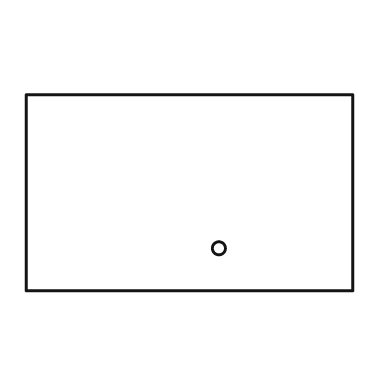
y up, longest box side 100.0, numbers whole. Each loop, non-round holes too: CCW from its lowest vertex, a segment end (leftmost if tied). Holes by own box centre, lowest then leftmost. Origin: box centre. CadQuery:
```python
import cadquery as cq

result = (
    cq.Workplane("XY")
    .moveTo(-50.0, -30.0)
    .lineTo(50.0, -30.0)
    .lineTo(50.0, 30.0)
    .lineTo(-50.0, 30.0)
    .close()
    .moveTo(9.0, -17.0)
    .circle(2.0)
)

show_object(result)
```